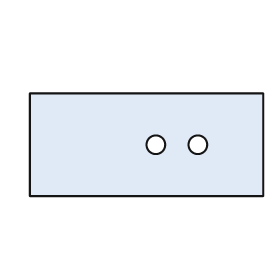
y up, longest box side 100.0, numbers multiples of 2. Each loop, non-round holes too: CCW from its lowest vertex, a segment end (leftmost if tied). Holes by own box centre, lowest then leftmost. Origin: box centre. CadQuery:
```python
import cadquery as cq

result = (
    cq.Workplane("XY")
    .moveTo(-50.0, -22.0)
    .lineTo(50.0, -22.0)
    .lineTo(50.0, 22.0)
    .lineTo(-50.0, 22.0)
    .close()
    .moveTo(4.0, 0.0)
    .circle(4.0)
    .moveTo(22.0, 0.0)
    .circle(4.0)
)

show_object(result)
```